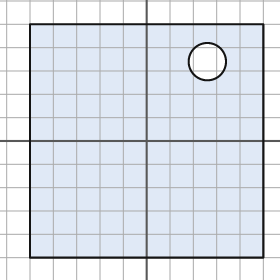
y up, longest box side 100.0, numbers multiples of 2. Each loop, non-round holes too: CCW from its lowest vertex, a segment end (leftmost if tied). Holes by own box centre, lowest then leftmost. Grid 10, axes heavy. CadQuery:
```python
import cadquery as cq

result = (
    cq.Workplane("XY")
    .moveTo(-50.0, -50.0)
    .lineTo(50.0, -50.0)
    .lineTo(50.0, 50.0)
    .lineTo(-50.0, 50.0)
    .close()
    .moveTo(26.0, 34.0)
    .circle(8.0)
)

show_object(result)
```